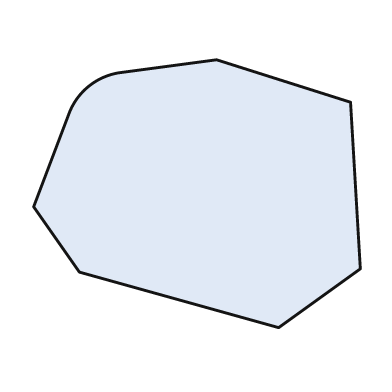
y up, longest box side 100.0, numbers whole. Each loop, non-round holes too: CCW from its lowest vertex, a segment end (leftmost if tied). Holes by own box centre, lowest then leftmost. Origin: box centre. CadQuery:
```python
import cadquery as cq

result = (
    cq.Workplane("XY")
    .moveTo(25.0, -41.0)
    .lineTo(50.0, -23.0)
    .lineTo(47.0, 28.0)
    .lineTo(6.0, 41.0)
    .lineTo(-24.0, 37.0)
    .threePointArc((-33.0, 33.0), (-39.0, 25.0))
    .lineTo(-50.0, -4.0)
    .lineTo(-36.0, -24.0)
    .close()
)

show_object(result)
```